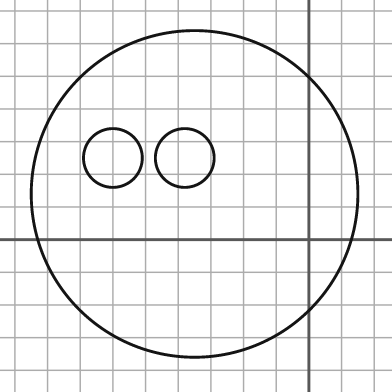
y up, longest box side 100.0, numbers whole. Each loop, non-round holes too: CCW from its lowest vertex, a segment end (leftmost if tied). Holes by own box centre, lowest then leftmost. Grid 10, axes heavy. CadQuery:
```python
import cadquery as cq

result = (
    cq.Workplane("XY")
    .moveTo(-35.0, 14.0)
    .circle(50.0)
    .moveTo(-60.0, 25.0)
    .circle(9.0)
    .moveTo(-38.0, 25.0)
    .circle(9.0)
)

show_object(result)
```